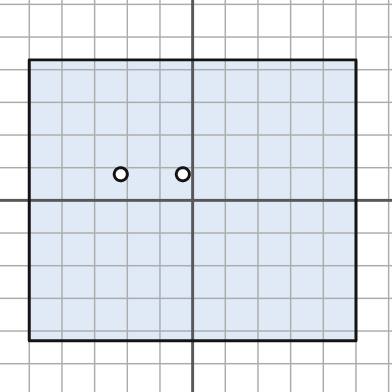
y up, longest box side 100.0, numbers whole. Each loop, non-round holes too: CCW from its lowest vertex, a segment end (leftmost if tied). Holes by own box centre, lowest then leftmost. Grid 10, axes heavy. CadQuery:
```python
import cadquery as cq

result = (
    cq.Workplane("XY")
    .moveTo(-50.0, -43.0)
    .lineTo(50.0, -43.0)
    .lineTo(50.0, 43.0)
    .lineTo(-50.0, 43.0)
    .close()
    .moveTo(-22.0, 8.0)
    .circle(2.0)
    .moveTo(-3.0, 8.0)
    .circle(2.0)
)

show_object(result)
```